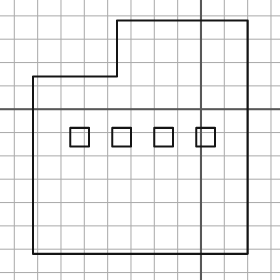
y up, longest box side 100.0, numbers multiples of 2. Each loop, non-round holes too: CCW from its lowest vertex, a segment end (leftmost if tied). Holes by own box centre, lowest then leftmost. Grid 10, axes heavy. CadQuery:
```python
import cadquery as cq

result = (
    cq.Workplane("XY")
    .moveTo(-72.0, -62.0)
    .lineTo(20.0, -62.0)
    .lineTo(20.0, 38.0)
    .lineTo(-36.0, 38.0)
    .lineTo(-36.0, 14.0)
    .lineTo(-72.0, 14.0)
    .close()
    .moveTo(-56.0, -16.0)
    .lineTo(-48.0, -16.0)
    .lineTo(-48.0, -8.0)
    .lineTo(-56.0, -8.0)
    .close()
    .moveTo(-38.0, -16.0)
    .lineTo(-30.0, -16.0)
    .lineTo(-30.0, -8.0)
    .lineTo(-38.0, -8.0)
    .close()
    .moveTo(-20.0, -16.0)
    .lineTo(-12.0, -16.0)
    .lineTo(-12.0, -8.0)
    .lineTo(-20.0, -8.0)
    .close()
    .moveTo(-2.0, -16.0)
    .lineTo(6.0, -16.0)
    .lineTo(6.0, -8.0)
    .lineTo(-2.0, -8.0)
    .close()
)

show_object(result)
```